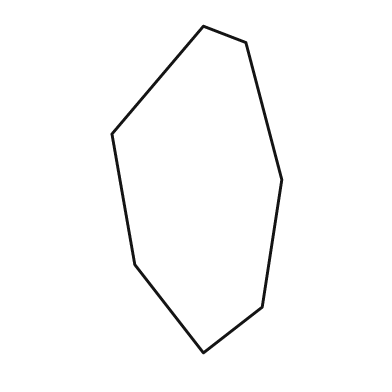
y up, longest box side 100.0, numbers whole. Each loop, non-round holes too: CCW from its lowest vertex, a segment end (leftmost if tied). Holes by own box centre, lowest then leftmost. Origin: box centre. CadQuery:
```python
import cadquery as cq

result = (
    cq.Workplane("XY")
    .moveTo(2.0, -50.0)
    .lineTo(20.0, -36.0)
    .lineTo(26.0, 3.0)
    .lineTo(15.0, 45.0)
    .lineTo(2.0, 50.0)
    .lineTo(-26.0, 17.0)
    .lineTo(-19.0, -23.0)
    .close()
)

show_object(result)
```